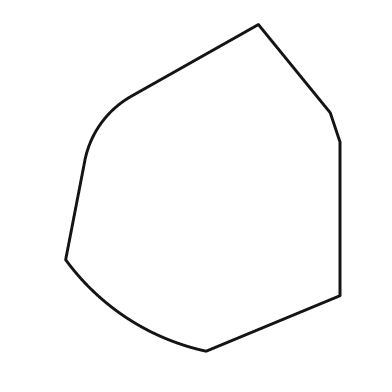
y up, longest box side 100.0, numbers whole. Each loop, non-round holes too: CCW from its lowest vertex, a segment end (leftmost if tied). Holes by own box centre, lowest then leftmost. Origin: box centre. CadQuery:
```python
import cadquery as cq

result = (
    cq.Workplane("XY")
    .moveTo(1.0, -50.0)
    .lineTo(42.0, -33.0)
    .lineTo(42.0, 14.0)
    .lineTo(39.0, 23.0)
    .lineTo(17.0, 50.0)
    .lineTo(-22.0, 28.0)
    .threePointArc((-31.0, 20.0), (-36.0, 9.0))
    .lineTo(-42.0, -22.0)
    .threePointArc((-23.0, -40.0), (1.0, -50.0))
    .close()
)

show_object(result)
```